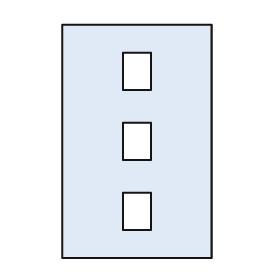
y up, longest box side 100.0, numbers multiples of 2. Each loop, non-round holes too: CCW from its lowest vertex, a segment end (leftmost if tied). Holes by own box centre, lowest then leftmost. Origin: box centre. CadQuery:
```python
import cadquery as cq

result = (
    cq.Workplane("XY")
    .moveTo(-32.0, -50.0)
    .lineTo(32.0, -50.0)
    .lineTo(32.0, 50.0)
    .lineTo(-32.0, 50.0)
    .close()
    .moveTo(-6.0, -38.0)
    .lineTo(6.0, -38.0)
    .lineTo(6.0, -22.0)
    .lineTo(-6.0, -22.0)
    .close()
    .moveTo(-6.0, -8.0)
    .lineTo(6.0, -8.0)
    .lineTo(6.0, 8.0)
    .lineTo(-6.0, 8.0)
    .close()
    .moveTo(-6.0, 22.0)
    .lineTo(6.0, 22.0)
    .lineTo(6.0, 38.0)
    .lineTo(-6.0, 38.0)
    .close()
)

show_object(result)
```